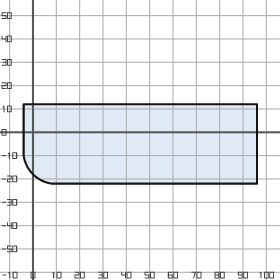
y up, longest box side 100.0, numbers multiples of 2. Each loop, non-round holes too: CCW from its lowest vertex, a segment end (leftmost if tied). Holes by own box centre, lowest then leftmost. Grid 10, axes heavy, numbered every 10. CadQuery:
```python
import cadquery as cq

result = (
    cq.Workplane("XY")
    .moveTo(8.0, -22.0)
    .lineTo(96.0, -22.0)
    .lineTo(96.0, 12.0)
    .lineTo(-4.0, 12.0)
    .lineTo(-4.0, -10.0)
    .threePointArc((0.0, -18.0), (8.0, -22.0))
    .close()
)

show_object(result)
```